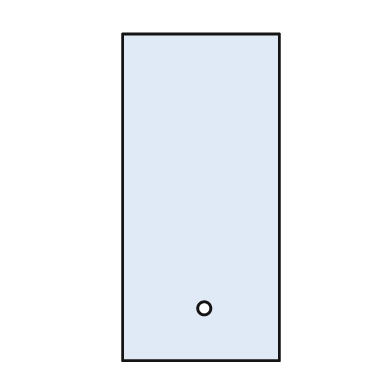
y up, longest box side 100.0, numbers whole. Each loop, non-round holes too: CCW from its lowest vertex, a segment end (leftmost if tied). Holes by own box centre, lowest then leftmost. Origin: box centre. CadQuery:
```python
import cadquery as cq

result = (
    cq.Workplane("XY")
    .moveTo(-24.0, -50.0)
    .lineTo(24.0, -50.0)
    .lineTo(24.0, 50.0)
    .lineTo(-24.0, 50.0)
    .close()
    .moveTo(1.0, -34.0)
    .circle(2.0)
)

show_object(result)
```